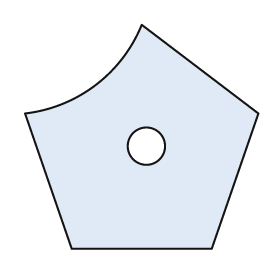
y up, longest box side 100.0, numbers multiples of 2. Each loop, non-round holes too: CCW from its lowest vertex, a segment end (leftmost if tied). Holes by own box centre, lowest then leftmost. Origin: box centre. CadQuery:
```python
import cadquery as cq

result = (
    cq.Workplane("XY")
    .moveTo(-30.0, -48.0)
    .lineTo(30.0, -48.0)
    .lineTo(50.0, 10.0)
    .lineTo(0.0, 48.0)
    .threePointArc((-20.0, 22.0), (-50.0, 10.0))
    .close()
    .moveTo(2.0, -4.0)
    .circle(8.0)
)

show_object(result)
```